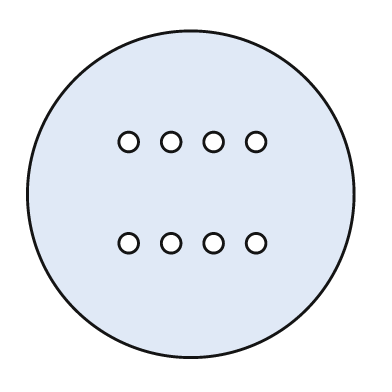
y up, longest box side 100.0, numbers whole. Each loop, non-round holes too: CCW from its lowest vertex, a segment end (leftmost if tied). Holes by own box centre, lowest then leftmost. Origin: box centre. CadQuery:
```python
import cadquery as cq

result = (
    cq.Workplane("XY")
    .moveTo(0.0, 0.0)
    .circle(50.0)
    .moveTo(-19.0, -15.0)
    .circle(3.0)
    .moveTo(-6.0, -15.0)
    .circle(3.0)
    .moveTo(7.0, -15.0)
    .circle(3.0)
    .moveTo(20.0, -15.0)
    .circle(3.0)
    .moveTo(-19.0, 16.0)
    .circle(3.0)
    .moveTo(-6.0, 16.0)
    .circle(3.0)
    .moveTo(7.0, 16.0)
    .circle(3.0)
    .moveTo(20.0, 16.0)
    .circle(3.0)
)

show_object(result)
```